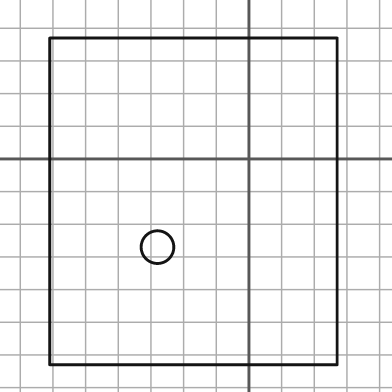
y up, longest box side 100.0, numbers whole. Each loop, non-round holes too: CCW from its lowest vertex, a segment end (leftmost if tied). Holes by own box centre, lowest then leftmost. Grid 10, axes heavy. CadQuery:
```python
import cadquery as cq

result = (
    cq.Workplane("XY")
    .moveTo(-61.0, -63.0)
    .lineTo(27.0, -63.0)
    .lineTo(27.0, 37.0)
    .lineTo(-61.0, 37.0)
    .close()
    .moveTo(-28.0, -27.0)
    .circle(5.0)
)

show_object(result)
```